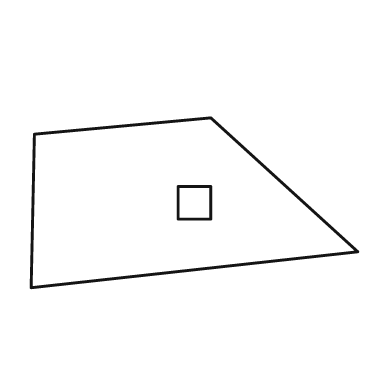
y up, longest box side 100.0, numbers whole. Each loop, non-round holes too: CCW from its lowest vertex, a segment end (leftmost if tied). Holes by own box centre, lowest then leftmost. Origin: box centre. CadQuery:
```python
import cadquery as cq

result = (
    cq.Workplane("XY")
    .moveTo(-50.0, -26.0)
    .lineTo(50.0, -15.0)
    .lineTo(5.0, 26.0)
    .lineTo(-49.0, 21.0)
    .close()
    .moveTo(-5.0, -5.0)
    .lineTo(5.0, -5.0)
    .lineTo(5.0, 5.0)
    .lineTo(-5.0, 5.0)
    .close()
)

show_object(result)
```